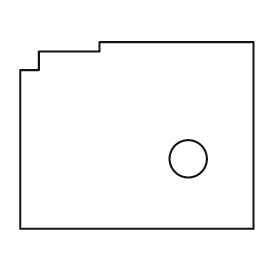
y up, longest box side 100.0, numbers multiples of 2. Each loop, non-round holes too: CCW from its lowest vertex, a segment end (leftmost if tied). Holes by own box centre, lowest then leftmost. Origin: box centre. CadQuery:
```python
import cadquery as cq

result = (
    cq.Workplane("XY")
    .moveTo(-50.0, -40.0)
    .lineTo(50.0, -40.0)
    .lineTo(50.0, 40.0)
    .lineTo(-16.0, 40.0)
    .lineTo(-16.0, 36.0)
    .lineTo(-42.0, 36.0)
    .lineTo(-42.0, 28.0)
    .lineTo(-50.0, 28.0)
    .close()
    .moveTo(22.0, -10.0)
    .circle(8.0)
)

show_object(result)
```